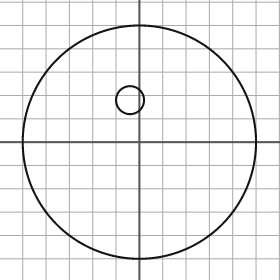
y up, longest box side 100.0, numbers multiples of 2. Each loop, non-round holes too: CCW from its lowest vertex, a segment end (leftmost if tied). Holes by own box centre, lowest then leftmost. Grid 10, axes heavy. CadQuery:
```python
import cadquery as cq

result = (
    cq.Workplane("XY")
    .moveTo(0.0, 0.0)
    .circle(50.0)
    .moveTo(-4.0, 18.0)
    .circle(6.0)
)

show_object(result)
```